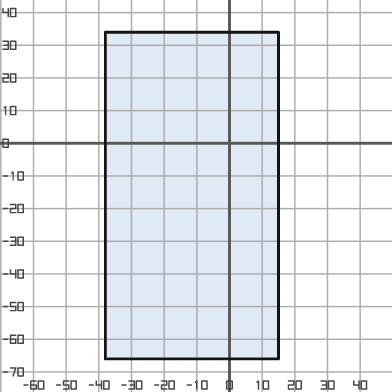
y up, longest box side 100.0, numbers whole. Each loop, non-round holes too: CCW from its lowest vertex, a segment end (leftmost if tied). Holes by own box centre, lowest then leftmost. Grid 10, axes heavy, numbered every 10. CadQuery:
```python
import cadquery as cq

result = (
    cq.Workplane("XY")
    .moveTo(-38.0, -66.0)
    .lineTo(15.0, -66.0)
    .lineTo(15.0, 34.0)
    .lineTo(-38.0, 34.0)
    .close()
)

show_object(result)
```